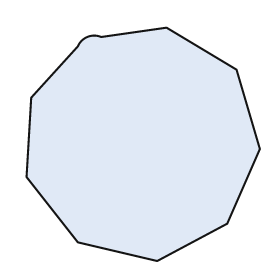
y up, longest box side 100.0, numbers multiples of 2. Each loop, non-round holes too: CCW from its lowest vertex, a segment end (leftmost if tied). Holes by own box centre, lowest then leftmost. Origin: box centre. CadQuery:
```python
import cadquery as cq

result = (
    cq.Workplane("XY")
    .moveTo(6.0, -50.0)
    .lineTo(36.0, -34.0)
    .lineTo(50.0, -2.0)
    .lineTo(40.0, 32.0)
    .lineTo(10.0, 50.0)
    .lineTo(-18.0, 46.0)
    .threePointArc((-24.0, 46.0), (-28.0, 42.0))
    .lineTo(-48.0, 20.0)
    .lineTo(-50.0, -14.0)
    .lineTo(-28.0, -42.0)
    .close()
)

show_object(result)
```